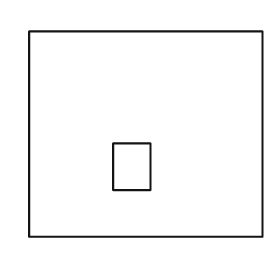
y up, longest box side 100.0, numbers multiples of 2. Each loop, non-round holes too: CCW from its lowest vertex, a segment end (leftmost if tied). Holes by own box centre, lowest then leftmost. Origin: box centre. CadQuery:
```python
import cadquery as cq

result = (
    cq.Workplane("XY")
    .moveTo(-50.0, -44.0)
    .lineTo(50.0, -44.0)
    .lineTo(50.0, 44.0)
    .lineTo(-50.0, 44.0)
    .close()
    .moveTo(-14.0, -24.0)
    .lineTo(2.0, -24.0)
    .lineTo(2.0, -4.0)
    .lineTo(-14.0, -4.0)
    .close()
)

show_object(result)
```